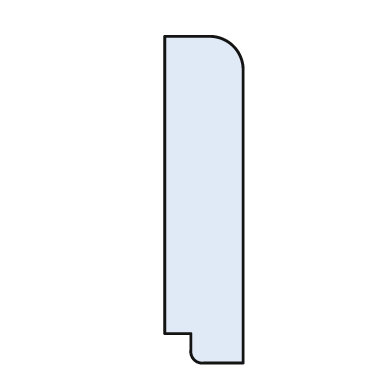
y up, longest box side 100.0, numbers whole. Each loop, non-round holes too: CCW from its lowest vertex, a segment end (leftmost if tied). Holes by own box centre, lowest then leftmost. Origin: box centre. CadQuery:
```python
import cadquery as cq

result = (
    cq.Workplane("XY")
    .moveTo(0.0, -50.0)
    .lineTo(12.0, -50.0)
    .lineTo(12.0, 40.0)
    .threePointArc((9.0, 47.0), (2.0, 50.0))
    .lineTo(-12.0, 50.0)
    .lineTo(-12.0, -41.0)
    .lineTo(-4.0, -41.0)
    .lineTo(-4.0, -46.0)
    .threePointArc((-3.0, -49.0), (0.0, -50.0))
    .close()
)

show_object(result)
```